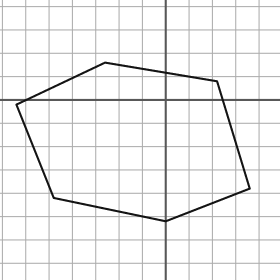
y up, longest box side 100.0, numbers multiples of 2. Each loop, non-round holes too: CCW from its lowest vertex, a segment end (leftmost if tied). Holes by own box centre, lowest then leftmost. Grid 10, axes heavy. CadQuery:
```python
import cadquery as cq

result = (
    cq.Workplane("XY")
    .moveTo(0.0, -52.0)
    .lineTo(36.0, -38.0)
    .lineTo(22.0, 8.0)
    .lineTo(-26.0, 16.0)
    .lineTo(-64.0, -2.0)
    .lineTo(-48.0, -42.0)
    .close()
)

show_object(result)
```